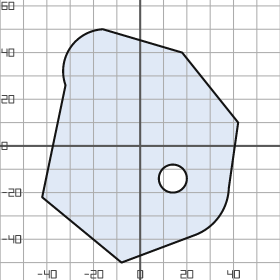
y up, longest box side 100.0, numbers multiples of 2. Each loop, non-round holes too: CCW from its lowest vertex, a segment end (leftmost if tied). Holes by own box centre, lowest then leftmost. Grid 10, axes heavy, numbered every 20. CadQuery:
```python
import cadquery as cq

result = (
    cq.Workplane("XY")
    .moveTo(-8.0, -50.0)
    .lineTo(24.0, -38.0)
    .threePointArc((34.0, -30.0), (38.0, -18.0))
    .lineTo(42.0, 10.0)
    .lineTo(18.0, 40.0)
    .lineTo(-16.0, 50.0)
    .threePointArc((-30.0, 42.0), (-32.0, 26.0))
    .lineTo(-42.0, -22.0)
    .close()
    .moveTo(14.0, -14.0)
    .circle(6.0)
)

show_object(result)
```